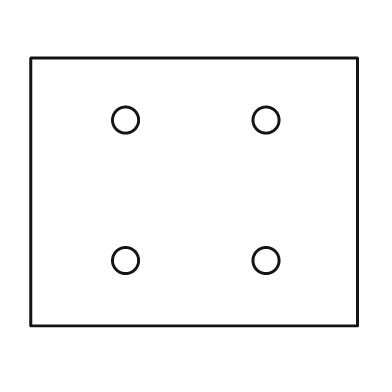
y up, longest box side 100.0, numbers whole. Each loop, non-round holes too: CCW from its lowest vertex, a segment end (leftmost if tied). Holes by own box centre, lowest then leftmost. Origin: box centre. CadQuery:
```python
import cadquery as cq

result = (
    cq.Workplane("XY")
    .moveTo(-50.0, -41.0)
    .lineTo(50.0, -41.0)
    .lineTo(50.0, 41.0)
    .lineTo(-50.0, 41.0)
    .close()
    .moveTo(-21.0, -21.0)
    .circle(4.0)
    .moveTo(22.0, -21.0)
    .circle(4.0)
    .moveTo(-21.0, 22.0)
    .circle(4.0)
    .moveTo(22.0, 22.0)
    .circle(4.0)
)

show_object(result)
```